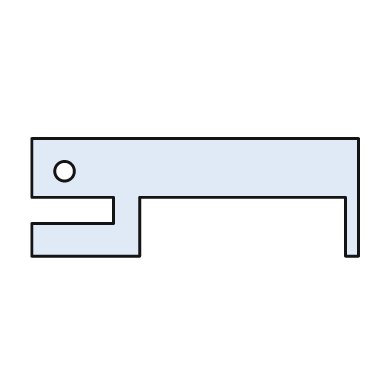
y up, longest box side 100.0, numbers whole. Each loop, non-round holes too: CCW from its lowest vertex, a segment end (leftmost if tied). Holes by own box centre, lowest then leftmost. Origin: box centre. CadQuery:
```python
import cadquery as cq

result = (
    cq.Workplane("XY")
    .moveTo(-50.0, -18.0)
    .lineTo(-17.0, -18.0)
    .lineTo(-17.0, 0.0)
    .lineTo(46.0, 0.0)
    .lineTo(46.0, -18.0)
    .lineTo(50.0, -18.0)
    .lineTo(50.0, 18.0)
    .lineTo(-50.0, 18.0)
    .lineTo(-50.0, 0.0)
    .lineTo(-25.0, 0.0)
    .lineTo(-25.0, -8.0)
    .lineTo(-50.0, -8.0)
    .close()
    .moveTo(-40.0, 8.0)
    .circle(3.0)
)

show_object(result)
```